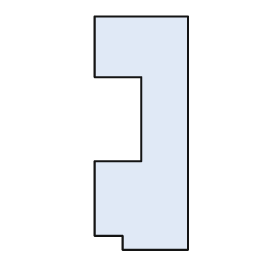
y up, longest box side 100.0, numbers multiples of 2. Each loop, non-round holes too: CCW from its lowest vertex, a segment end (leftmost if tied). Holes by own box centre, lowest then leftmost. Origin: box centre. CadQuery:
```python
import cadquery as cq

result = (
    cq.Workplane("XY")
    .moveTo(-8.0, -50.0)
    .lineTo(20.0, -50.0)
    .lineTo(20.0, 50.0)
    .lineTo(-20.0, 50.0)
    .lineTo(-20.0, 24.0)
    .lineTo(0.0, 24.0)
    .lineTo(0.0, -12.0)
    .lineTo(-20.0, -12.0)
    .lineTo(-20.0, -44.0)
    .lineTo(-8.0, -44.0)
    .close()
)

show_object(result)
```